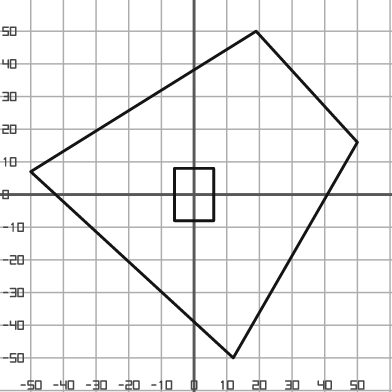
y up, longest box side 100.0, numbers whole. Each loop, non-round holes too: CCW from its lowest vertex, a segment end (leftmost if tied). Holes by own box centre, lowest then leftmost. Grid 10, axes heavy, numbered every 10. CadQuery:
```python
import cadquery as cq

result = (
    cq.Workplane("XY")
    .moveTo(12.0, -50.0)
    .lineTo(50.0, 16.0)
    .lineTo(19.0, 50.0)
    .lineTo(-50.0, 7.0)
    .close()
    .moveTo(-6.0, -8.0)
    .lineTo(6.0, -8.0)
    .lineTo(6.0, 8.0)
    .lineTo(-6.0, 8.0)
    .close()
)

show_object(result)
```